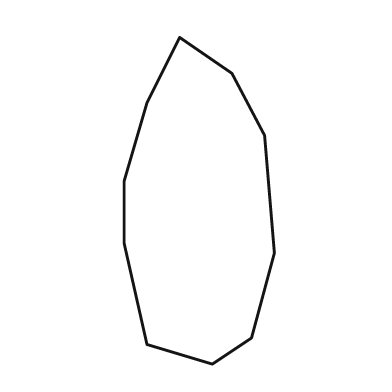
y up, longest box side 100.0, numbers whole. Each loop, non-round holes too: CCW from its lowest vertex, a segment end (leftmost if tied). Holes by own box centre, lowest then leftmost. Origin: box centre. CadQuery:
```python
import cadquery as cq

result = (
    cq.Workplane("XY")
    .moveTo(4.0, -50.0)
    .lineTo(16.0, -42.0)
    .lineTo(23.0, -16.0)
    .lineTo(20.0, 20.0)
    .lineTo(10.0, 39.0)
    .lineTo(-6.0, 50.0)
    .lineTo(-16.0, 30.0)
    .lineTo(-23.0, 6.0)
    .lineTo(-23.0, -13.0)
    .lineTo(-16.0, -44.0)
    .close()
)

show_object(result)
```